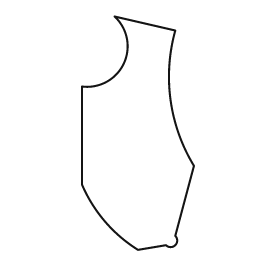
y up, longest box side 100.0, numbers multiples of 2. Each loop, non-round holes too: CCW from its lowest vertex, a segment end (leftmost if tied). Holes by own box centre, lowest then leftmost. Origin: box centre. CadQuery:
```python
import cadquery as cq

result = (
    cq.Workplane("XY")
    .moveTo(0.0, -50.0)
    .lineTo(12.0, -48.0)
    .threePointArc((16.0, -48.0), (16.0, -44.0))
    .lineTo(24.0, -14.0)
    .threePointArc((14.0, 14.0), (16.0, 44.0))
    .lineTo(-10.0, 50.0)
    .threePointArc((-6.0, 30.0), (-24.0, 20.0))
    .lineTo(-24.0, -22.0)
    .threePointArc((-14.0, -38.0), (0.0, -50.0))
    .close()
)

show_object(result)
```